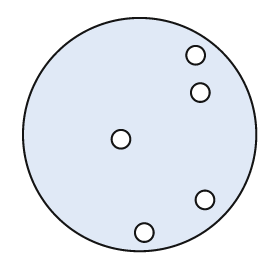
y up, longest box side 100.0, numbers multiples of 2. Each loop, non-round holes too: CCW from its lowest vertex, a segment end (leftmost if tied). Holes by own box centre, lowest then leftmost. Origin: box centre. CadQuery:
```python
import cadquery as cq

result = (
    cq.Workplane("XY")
    .moveTo(0.0, 0.0)
    .circle(50.0)
    .moveTo(2.0, -42.0)
    .circle(4.0)
    .moveTo(28.0, -28.0)
    .circle(4.0)
    .moveTo(-8.0, -2.0)
    .circle(4.0)
    .moveTo(26.0, 18.0)
    .circle(4.0)
    .moveTo(24.0, 34.0)
    .circle(4.0)
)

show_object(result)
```